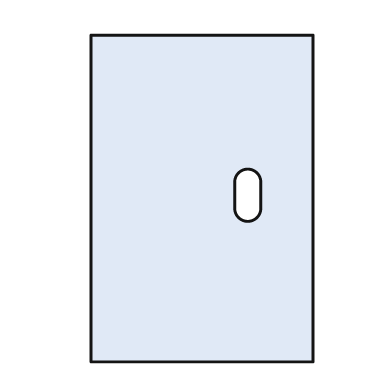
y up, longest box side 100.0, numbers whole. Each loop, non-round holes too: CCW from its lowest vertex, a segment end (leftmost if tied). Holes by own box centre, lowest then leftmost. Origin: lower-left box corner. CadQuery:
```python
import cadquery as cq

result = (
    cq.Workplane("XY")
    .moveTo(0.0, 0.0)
    .lineTo(68.0, 0.0)
    .lineTo(68.0, 100.0)
    .lineTo(0.0, 100.0)
    .close()
    .moveTo(44.0, 47.0)
    .threePointArc((48.0, 43.0), (52.0, 47.0))
    .lineTo(52.0, 55.0)
    .threePointArc((48.0, 59.0), (44.0, 55.0))
    .close()
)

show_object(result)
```